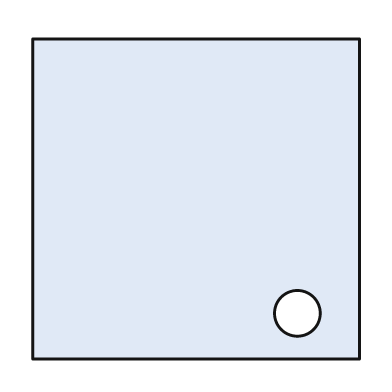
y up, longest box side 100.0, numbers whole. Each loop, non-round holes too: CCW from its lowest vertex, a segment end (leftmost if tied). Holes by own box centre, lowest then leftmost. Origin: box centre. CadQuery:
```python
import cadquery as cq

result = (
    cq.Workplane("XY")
    .moveTo(-50.0, -49.0)
    .lineTo(50.0, -49.0)
    .lineTo(50.0, 49.0)
    .lineTo(-50.0, 49.0)
    .close()
    .moveTo(31.0, -35.0)
    .circle(7.0)
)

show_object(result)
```